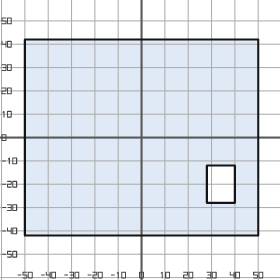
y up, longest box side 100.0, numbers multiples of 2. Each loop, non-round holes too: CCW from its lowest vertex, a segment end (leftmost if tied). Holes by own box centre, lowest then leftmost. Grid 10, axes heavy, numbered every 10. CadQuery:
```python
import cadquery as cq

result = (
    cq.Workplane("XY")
    .moveTo(-50.0, -42.0)
    .lineTo(50.0, -42.0)
    .lineTo(50.0, 42.0)
    .lineTo(-50.0, 42.0)
    .close()
    .moveTo(28.0, -28.0)
    .lineTo(40.0, -28.0)
    .lineTo(40.0, -12.0)
    .lineTo(28.0, -12.0)
    .close()
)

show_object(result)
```